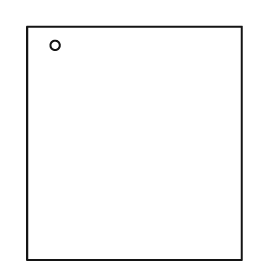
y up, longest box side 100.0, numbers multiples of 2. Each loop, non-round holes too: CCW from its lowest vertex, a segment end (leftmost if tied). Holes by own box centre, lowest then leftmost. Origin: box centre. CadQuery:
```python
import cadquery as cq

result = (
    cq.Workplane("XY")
    .moveTo(-46.0, -50.0)
    .lineTo(46.0, -50.0)
    .lineTo(46.0, 50.0)
    .lineTo(-46.0, 50.0)
    .close()
    .moveTo(-34.0, 42.0)
    .circle(2.0)
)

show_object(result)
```